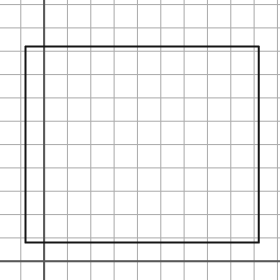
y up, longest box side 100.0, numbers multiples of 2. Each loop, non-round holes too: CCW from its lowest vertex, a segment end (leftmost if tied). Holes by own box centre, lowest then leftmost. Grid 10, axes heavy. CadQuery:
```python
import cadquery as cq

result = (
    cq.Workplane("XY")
    .moveTo(-8.0, 8.0)
    .lineTo(92.0, 8.0)
    .lineTo(92.0, 92.0)
    .lineTo(-8.0, 92.0)
    .close()
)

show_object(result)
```